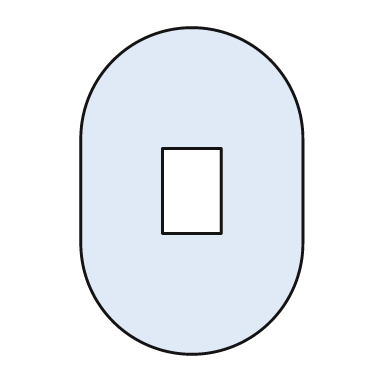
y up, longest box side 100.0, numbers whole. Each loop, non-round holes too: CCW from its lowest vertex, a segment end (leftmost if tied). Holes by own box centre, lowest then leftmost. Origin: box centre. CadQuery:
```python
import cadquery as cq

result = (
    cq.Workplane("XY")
    .moveTo(-34.0, -16.0)
    .threePointArc((0.0, -50.0), (34.0, -16.0))
    .lineTo(34.0, 16.0)
    .threePointArc((0.0, 50.0), (-34.0, 16.0))
    .close()
    .moveTo(-9.0, -13.0)
    .lineTo(9.0, -13.0)
    .lineTo(9.0, 13.0)
    .lineTo(-9.0, 13.0)
    .close()
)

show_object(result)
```